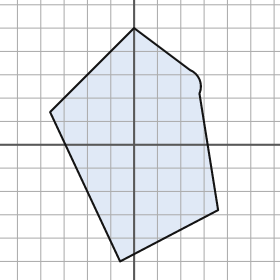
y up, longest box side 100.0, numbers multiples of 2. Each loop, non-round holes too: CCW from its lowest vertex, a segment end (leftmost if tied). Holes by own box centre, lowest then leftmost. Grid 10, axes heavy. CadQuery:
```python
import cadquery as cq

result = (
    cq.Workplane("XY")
    .moveTo(-6.0, -50.0)
    .lineTo(36.0, -28.0)
    .lineTo(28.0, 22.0)
    .threePointArc((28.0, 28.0), (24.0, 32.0))
    .lineTo(0.0, 50.0)
    .lineTo(-36.0, 14.0)
    .close()
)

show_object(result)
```